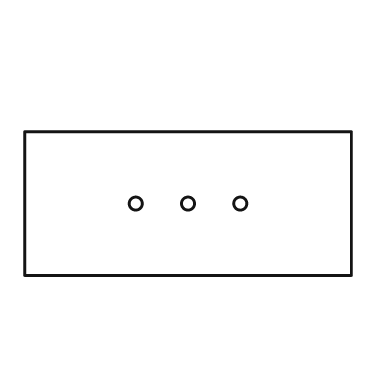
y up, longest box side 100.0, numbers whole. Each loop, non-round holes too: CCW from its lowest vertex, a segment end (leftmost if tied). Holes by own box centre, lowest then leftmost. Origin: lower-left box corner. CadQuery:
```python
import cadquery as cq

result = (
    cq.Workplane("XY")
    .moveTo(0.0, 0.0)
    .lineTo(100.0, 0.0)
    .lineTo(100.0, 44.0)
    .lineTo(0.0, 44.0)
    .close()
    .moveTo(34.0, 22.0)
    .circle(2.0)
    .moveTo(50.0, 22.0)
    .circle(2.0)
    .moveTo(66.0, 22.0)
    .circle(2.0)
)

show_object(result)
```